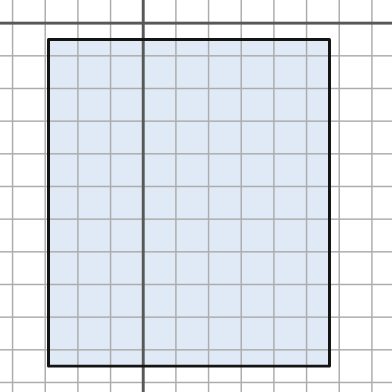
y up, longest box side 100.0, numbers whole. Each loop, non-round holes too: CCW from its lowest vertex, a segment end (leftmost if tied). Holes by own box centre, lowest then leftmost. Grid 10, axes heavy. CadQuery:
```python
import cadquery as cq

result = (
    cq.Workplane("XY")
    .moveTo(-29.0, -105.0)
    .lineTo(57.0, -105.0)
    .lineTo(57.0, -5.0)
    .lineTo(-29.0, -5.0)
    .close()
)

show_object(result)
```